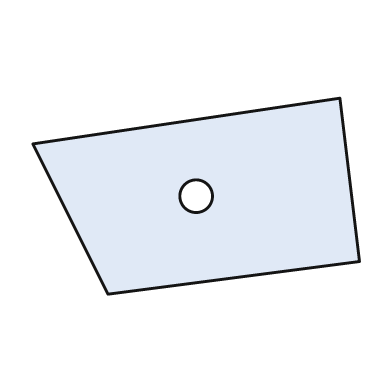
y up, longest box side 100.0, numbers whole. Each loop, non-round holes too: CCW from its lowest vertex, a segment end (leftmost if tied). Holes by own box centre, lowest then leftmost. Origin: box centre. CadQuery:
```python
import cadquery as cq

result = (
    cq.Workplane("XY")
    .moveTo(-27.0, -30.0)
    .lineTo(50.0, -20.0)
    .lineTo(44.0, 30.0)
    .lineTo(-50.0, 16.0)
    .close()
    .moveTo(0.0, 0.0)
    .circle(5.0)
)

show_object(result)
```